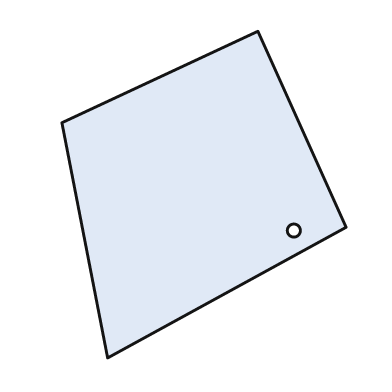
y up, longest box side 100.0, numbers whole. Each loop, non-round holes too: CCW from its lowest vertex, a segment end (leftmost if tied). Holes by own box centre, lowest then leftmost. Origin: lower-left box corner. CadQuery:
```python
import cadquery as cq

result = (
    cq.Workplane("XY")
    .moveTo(14.0, 0.0)
    .lineTo(87.0, 40.0)
    .lineTo(60.0, 100.0)
    .lineTo(0.0, 72.0)
    .close()
    .moveTo(71.0, 39.0)
    .circle(2.0)
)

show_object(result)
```